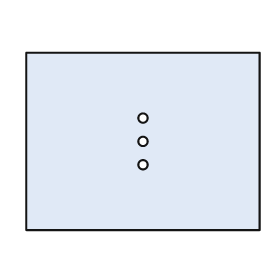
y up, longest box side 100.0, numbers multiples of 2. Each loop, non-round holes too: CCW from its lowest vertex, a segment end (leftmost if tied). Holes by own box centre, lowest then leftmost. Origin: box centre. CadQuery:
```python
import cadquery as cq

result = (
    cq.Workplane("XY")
    .moveTo(-50.0, -38.0)
    .lineTo(50.0, -38.0)
    .lineTo(50.0, 38.0)
    .lineTo(-50.0, 38.0)
    .close()
    .moveTo(0.0, -10.0)
    .circle(2.0)
    .moveTo(0.0, 0.0)
    .circle(2.0)
    .moveTo(0.0, 10.0)
    .circle(2.0)
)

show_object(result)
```